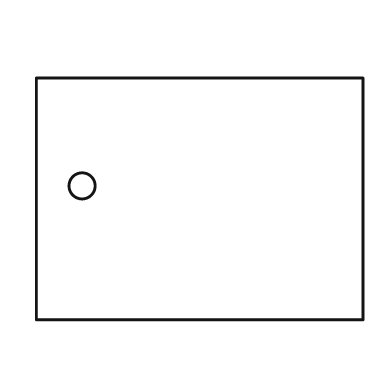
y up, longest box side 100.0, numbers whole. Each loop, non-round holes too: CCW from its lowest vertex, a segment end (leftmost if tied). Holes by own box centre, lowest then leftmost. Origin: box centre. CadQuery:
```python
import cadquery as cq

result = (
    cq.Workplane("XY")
    .moveTo(-50.0, -37.0)
    .lineTo(50.0, -37.0)
    .lineTo(50.0, 37.0)
    .lineTo(-50.0, 37.0)
    .close()
    .moveTo(-36.0, 4.0)
    .circle(4.0)
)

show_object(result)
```